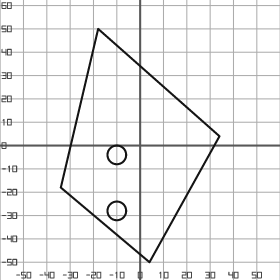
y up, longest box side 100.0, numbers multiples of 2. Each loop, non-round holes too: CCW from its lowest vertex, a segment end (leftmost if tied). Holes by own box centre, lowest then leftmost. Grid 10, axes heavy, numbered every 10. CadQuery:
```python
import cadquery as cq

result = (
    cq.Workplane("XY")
    .moveTo(4.0, -50.0)
    .lineTo(34.0, 4.0)
    .lineTo(-18.0, 50.0)
    .lineTo(-34.0, -18.0)
    .close()
    .moveTo(-10.0, -28.0)
    .circle(4.0)
    .moveTo(-10.0, -4.0)
    .circle(4.0)
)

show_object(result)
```